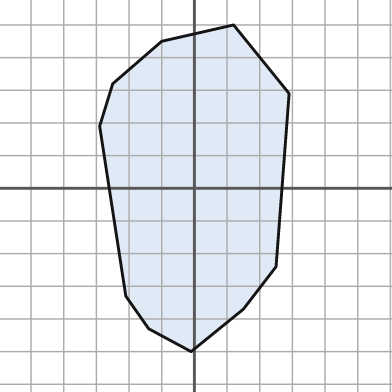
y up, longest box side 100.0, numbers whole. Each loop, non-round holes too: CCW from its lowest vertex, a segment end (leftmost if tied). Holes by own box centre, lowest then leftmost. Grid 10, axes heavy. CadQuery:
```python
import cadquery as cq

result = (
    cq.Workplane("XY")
    .moveTo(-1.0, -50.0)
    .lineTo(15.0, -37.0)
    .lineTo(25.0, -24.0)
    .lineTo(29.0, 29.0)
    .lineTo(12.0, 50.0)
    .lineTo(-10.0, 45.0)
    .lineTo(-25.0, 32.0)
    .lineTo(-29.0, 19.0)
    .lineTo(-21.0, -33.0)
    .lineTo(-14.0, -43.0)
    .close()
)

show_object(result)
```